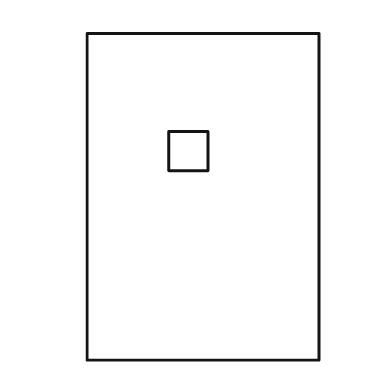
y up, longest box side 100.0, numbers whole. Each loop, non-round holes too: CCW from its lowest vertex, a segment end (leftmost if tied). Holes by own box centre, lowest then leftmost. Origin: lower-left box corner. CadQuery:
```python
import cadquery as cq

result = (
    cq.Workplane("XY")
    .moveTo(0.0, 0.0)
    .lineTo(71.0, 0.0)
    .lineTo(71.0, 100.0)
    .lineTo(0.0, 100.0)
    .close()
    .moveTo(25.0, 58.0)
    .lineTo(37.0, 58.0)
    .lineTo(37.0, 70.0)
    .lineTo(25.0, 70.0)
    .close()
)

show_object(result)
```